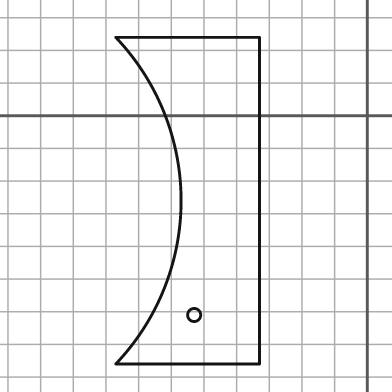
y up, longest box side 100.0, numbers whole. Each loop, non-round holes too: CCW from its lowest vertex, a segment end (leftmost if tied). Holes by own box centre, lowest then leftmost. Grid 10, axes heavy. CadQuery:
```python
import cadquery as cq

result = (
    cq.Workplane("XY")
    .moveTo(-77.0, -76.0)
    .lineTo(-33.0, -76.0)
    .lineTo(-33.0, 24.0)
    .lineTo(-77.0, 24.0)
    .threePointArc((-57.0, -26.0), (-77.0, -76.0))
    .close()
    .moveTo(-53.0, -61.0)
    .circle(2.0)
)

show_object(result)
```